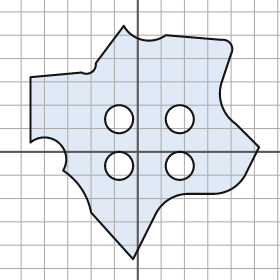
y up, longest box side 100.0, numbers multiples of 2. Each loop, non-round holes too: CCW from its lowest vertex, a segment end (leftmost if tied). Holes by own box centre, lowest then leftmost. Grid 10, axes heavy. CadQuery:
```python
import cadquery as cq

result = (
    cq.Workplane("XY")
    .moveTo(-2.0, -46.0)
    .lineTo(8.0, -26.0)
    .threePointArc((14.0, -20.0), (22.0, -18.0))
    .lineTo(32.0, -18.0)
    .threePointArc((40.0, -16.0), (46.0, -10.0))
    .lineTo(52.0, 2.0)
    .lineTo(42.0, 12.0)
    .threePointArc((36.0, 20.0), (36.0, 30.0))
    .lineTo(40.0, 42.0)
    .threePointArc((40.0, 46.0), (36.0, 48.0))
    .lineTo(12.0, 50.0)
    .threePointArc((2.0, 48.0), (-6.0, 54.0))
    .lineTo(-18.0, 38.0)
    .threePointArc((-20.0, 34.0), (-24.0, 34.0))
    .lineTo(-46.0, 32.0)
    .lineTo(-46.0, 4.0)
    .threePointArc((-34.0, 4.0), (-32.0, -8.0))
    .threePointArc((-24.0, -16.0), (-20.0, -26.0))
    .close()
    .moveTo(-8.0, -6.0)
    .circle(6.0)
    .moveTo(18.0, -6.0)
    .circle(6.0)
    .moveTo(-8.0, 14.0)
    .circle(6.0)
    .moveTo(18.0, 14.0)
    .circle(6.0)
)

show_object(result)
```